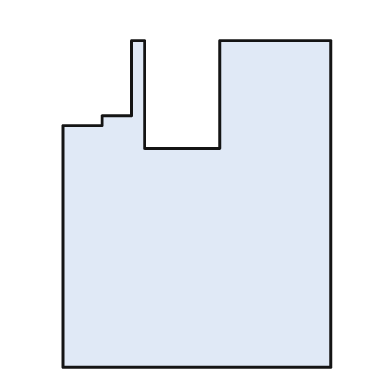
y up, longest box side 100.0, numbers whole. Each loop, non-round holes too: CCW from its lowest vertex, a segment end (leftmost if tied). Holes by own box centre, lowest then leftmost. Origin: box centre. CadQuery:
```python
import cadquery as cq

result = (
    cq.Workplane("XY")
    .moveTo(-41.0, -50.0)
    .lineTo(41.0, -50.0)
    .lineTo(41.0, 50.0)
    .lineTo(7.0, 50.0)
    .lineTo(7.0, 17.0)
    .lineTo(-16.0, 17.0)
    .lineTo(-16.0, 50.0)
    .lineTo(-20.0, 50.0)
    .lineTo(-20.0, 27.0)
    .lineTo(-29.0, 27.0)
    .lineTo(-29.0, 24.0)
    .lineTo(-41.0, 24.0)
    .close()
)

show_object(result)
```